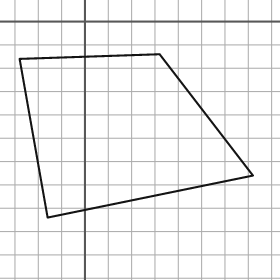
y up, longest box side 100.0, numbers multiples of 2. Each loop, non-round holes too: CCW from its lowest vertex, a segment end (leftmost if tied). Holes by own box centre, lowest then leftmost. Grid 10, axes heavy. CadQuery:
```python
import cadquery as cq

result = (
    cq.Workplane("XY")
    .moveTo(-16.0, -84.0)
    .lineTo(72.0, -66.0)
    .lineTo(32.0, -14.0)
    .lineTo(-28.0, -16.0)
    .close()
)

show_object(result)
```